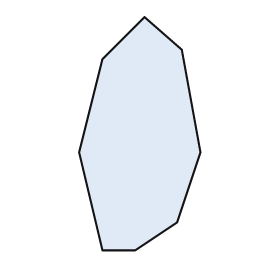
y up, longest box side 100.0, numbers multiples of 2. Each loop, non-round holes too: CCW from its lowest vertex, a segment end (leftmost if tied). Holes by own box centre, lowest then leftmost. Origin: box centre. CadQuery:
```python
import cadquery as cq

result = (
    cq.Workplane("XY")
    .moveTo(-16.0, -50.0)
    .lineTo(-2.0, -50.0)
    .lineTo(16.0, -38.0)
    .lineTo(26.0, -8.0)
    .lineTo(18.0, 36.0)
    .lineTo(2.0, 50.0)
    .lineTo(-16.0, 32.0)
    .lineTo(-26.0, -8.0)
    .close()
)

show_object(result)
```